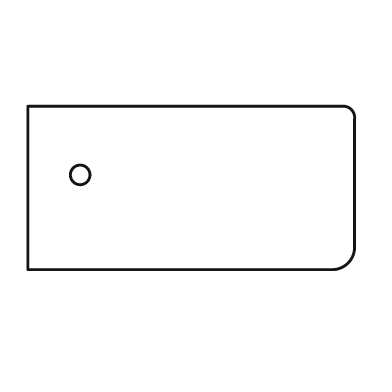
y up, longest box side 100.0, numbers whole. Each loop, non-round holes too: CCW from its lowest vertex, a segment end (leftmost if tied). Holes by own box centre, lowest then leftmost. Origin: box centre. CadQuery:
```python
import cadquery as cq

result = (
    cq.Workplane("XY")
    .moveTo(-50.0, -25.0)
    .lineTo(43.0, -25.0)
    .threePointArc((48.0, -23.0), (50.0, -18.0))
    .lineTo(50.0, 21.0)
    .threePointArc((49.0, 24.0), (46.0, 25.0))
    .lineTo(-50.0, 25.0)
    .close()
    .moveTo(-34.0, 4.0)
    .circle(3.0)
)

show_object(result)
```